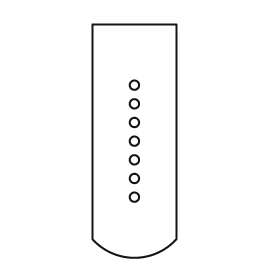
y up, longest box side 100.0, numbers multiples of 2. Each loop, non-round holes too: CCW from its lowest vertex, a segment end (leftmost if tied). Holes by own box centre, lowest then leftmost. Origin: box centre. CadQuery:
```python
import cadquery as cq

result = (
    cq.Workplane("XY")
    .moveTo(-18.0, -42.0)
    .threePointArc((0.0, -50.0), (18.0, -42.0))
    .lineTo(18.0, 50.0)
    .lineTo(-18.0, 50.0)
    .close()
    .moveTo(0.0, -24.0)
    .circle(2.0)
    .moveTo(0.0, -16.0)
    .circle(2.0)
    .moveTo(0.0, -8.0)
    .circle(2.0)
    .moveTo(0.0, 0.0)
    .circle(2.0)
    .moveTo(0.0, 8.0)
    .circle(2.0)
    .moveTo(0.0, 16.0)
    .circle(2.0)
    .moveTo(0.0, 24.0)
    .circle(2.0)
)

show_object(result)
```